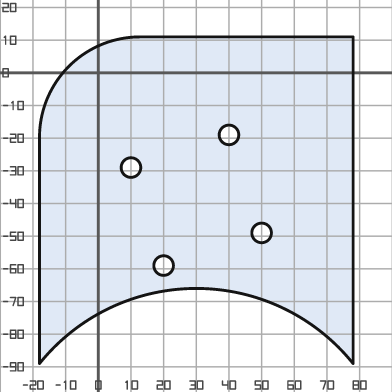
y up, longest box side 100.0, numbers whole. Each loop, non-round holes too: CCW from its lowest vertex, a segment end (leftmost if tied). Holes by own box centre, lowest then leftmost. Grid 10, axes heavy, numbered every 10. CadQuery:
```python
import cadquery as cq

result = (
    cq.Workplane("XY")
    .moveTo(-18.0, -89.0)
    .threePointArc((30.0, -66.0), (78.0, -89.0))
    .lineTo(78.0, 11.0)
    .lineTo(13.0, 11.0)
    .threePointArc((-9.0, 2.0), (-18.0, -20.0))
    .close()
    .moveTo(20.0, -59.0)
    .circle(3.0)
    .moveTo(50.0, -49.0)
    .circle(3.0)
    .moveTo(10.0, -29.0)
    .circle(3.0)
    .moveTo(40.0, -19.0)
    .circle(3.0)
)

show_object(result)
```